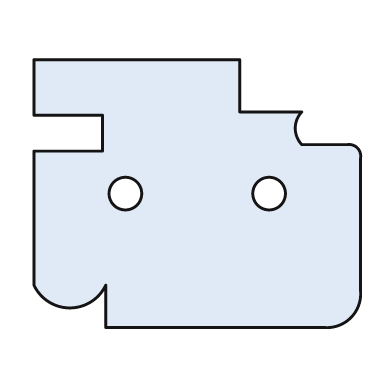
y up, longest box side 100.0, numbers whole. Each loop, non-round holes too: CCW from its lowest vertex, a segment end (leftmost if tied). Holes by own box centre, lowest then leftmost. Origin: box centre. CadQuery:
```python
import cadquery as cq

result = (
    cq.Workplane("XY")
    .moveTo(-28.0, -41.0)
    .lineTo(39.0, -41.0)
    .threePointArc((47.0, -38.0), (50.0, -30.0))
    .lineTo(50.0, 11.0)
    .threePointArc((49.0, 14.0), (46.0, 15.0))
    .lineTo(32.0, 15.0)
    .threePointArc((30.0, 20.0), (32.0, 25.0))
    .lineTo(13.0, 25.0)
    .lineTo(13.0, 41.0)
    .lineTo(-50.0, 41.0)
    .lineTo(-50.0, 24.0)
    .lineTo(-29.0, 24.0)
    .lineTo(-29.0, 13.0)
    .lineTo(-50.0, 13.0)
    .lineTo(-50.0, -28.0)
    .threePointArc((-39.0, -35.0), (-28.0, -28.0))
    .close()
    .moveTo(-22.0, 0.0)
    .circle(5.0)
    .moveTo(22.0, 0.0)
    .circle(5.0)
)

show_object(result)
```